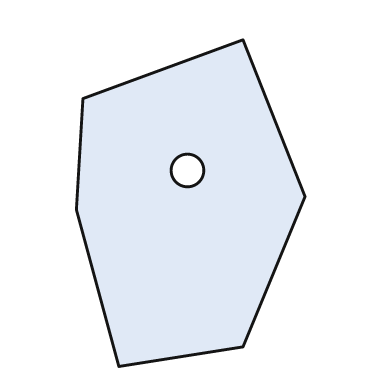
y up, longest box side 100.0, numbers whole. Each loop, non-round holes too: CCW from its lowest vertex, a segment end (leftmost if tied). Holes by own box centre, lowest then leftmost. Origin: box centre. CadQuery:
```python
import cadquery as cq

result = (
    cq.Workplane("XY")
    .moveTo(-22.0, -50.0)
    .lineTo(16.0, -44.0)
    .lineTo(35.0, 2.0)
    .lineTo(16.0, 50.0)
    .lineTo(-33.0, 32.0)
    .lineTo(-35.0, -2.0)
    .close()
    .moveTo(-1.0, 10.0)
    .circle(5.0)
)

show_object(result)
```